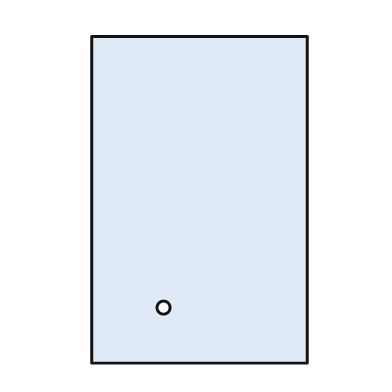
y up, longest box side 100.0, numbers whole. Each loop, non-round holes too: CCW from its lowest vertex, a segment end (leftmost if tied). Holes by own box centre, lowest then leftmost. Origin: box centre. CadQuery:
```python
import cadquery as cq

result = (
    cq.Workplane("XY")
    .moveTo(-33.0, -50.0)
    .lineTo(33.0, -50.0)
    .lineTo(33.0, 50.0)
    .lineTo(-33.0, 50.0)
    .close()
    .moveTo(-11.0, -33.0)
    .circle(2.0)
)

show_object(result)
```